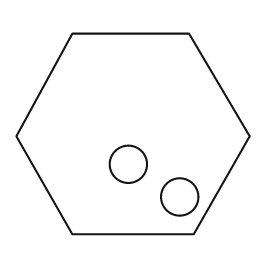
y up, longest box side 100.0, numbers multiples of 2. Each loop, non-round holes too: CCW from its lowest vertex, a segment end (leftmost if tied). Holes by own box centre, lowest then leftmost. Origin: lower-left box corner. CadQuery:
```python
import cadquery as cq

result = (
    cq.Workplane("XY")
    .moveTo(24.0, 0.0)
    .lineTo(76.0, 0.0)
    .lineTo(100.0, 42.0)
    .lineTo(74.0, 86.0)
    .lineTo(24.0, 86.0)
    .lineTo(0.0, 42.0)
    .close()
    .moveTo(70.0, 16.0)
    .circle(8.0)
    .moveTo(48.0, 30.0)
    .circle(8.0)
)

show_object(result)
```